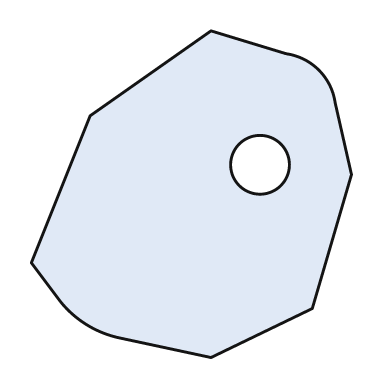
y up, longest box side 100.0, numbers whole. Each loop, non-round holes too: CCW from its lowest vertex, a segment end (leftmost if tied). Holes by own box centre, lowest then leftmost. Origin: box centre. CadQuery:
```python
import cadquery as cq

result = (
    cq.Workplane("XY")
    .moveTo(6.0, -50.0)
    .lineTo(37.0, -35.0)
    .lineTo(49.0, 6.0)
    .lineTo(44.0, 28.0)
    .threePointArc((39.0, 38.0), (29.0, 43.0))
    .lineTo(6.0, 50.0)
    .lineTo(-31.0, 24.0)
    .lineTo(-49.0, -21.0)
    .lineTo(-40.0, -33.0)
    .threePointArc((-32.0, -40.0), (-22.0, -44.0))
    .close()
    .moveTo(21.0, 9.0)
    .circle(9.0)
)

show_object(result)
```